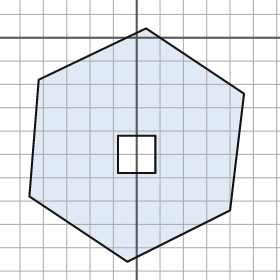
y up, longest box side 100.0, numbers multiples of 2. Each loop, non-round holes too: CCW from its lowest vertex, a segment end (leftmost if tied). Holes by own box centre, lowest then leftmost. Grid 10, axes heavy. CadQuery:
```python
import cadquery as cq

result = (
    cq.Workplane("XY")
    .moveTo(-4.0, -96.0)
    .lineTo(40.0, -74.0)
    .lineTo(46.0, -24.0)
    .lineTo(4.0, 4.0)
    .lineTo(-42.0, -18.0)
    .lineTo(-46.0, -68.0)
    .close()
    .moveTo(-8.0, -58.0)
    .lineTo(8.0, -58.0)
    .lineTo(8.0, -42.0)
    .lineTo(-8.0, -42.0)
    .close()
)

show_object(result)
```